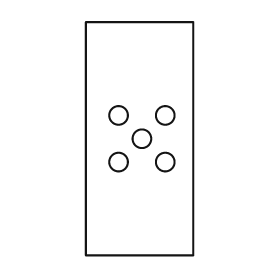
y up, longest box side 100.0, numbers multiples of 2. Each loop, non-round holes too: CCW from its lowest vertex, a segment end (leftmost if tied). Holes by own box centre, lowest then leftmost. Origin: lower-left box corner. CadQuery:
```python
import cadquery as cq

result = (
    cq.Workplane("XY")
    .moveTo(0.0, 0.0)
    .lineTo(46.0, 0.0)
    .lineTo(46.0, 100.0)
    .lineTo(0.0, 100.0)
    .close()
    .moveTo(14.0, 40.0)
    .circle(4.0)
    .moveTo(34.0, 40.0)
    .circle(4.0)
    .moveTo(24.0, 50.0)
    .circle(4.0)
    .moveTo(14.0, 60.0)
    .circle(4.0)
    .moveTo(34.0, 60.0)
    .circle(4.0)
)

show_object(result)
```